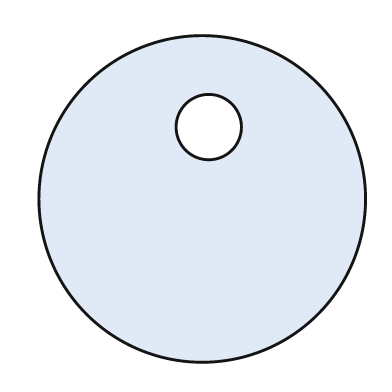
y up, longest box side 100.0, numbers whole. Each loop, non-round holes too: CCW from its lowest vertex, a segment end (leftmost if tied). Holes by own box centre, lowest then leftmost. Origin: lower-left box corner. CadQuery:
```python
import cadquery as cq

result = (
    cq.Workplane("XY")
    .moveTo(50.0, 50.0)
    .circle(50.0)
    .moveTo(52.0, 72.0)
    .circle(10.0)
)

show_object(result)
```